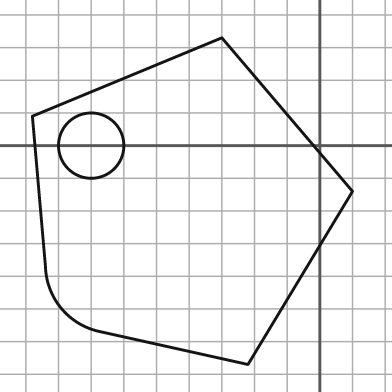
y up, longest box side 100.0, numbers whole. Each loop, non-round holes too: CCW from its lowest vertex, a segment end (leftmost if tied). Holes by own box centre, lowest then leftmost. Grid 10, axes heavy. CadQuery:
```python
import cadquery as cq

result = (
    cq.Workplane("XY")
    .moveTo(-22.0, -67.0)
    .lineTo(10.0, -14.0)
    .lineTo(-30.0, 33.0)
    .lineTo(-88.0, 9.0)
    .lineTo(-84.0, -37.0)
    .threePointArc((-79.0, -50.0), (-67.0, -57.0))
    .close()
    .moveTo(-70.0, 0.0)
    .circle(10.0)
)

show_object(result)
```